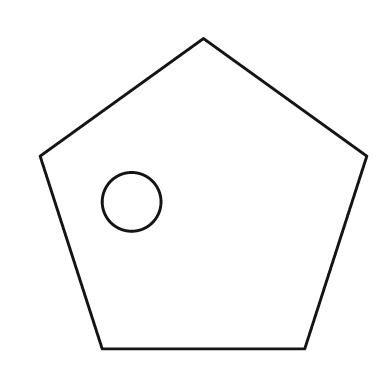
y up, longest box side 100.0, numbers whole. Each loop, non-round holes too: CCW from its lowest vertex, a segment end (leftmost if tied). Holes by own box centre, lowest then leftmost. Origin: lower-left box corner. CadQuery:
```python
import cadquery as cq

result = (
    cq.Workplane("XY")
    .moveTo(19.0, 0.0)
    .lineTo(81.0, 0.0)
    .lineTo(100.0, 59.0)
    .lineTo(50.0, 95.0)
    .lineTo(0.0, 59.0)
    .close()
    .moveTo(28.0, 45.0)
    .circle(9.0)
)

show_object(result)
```